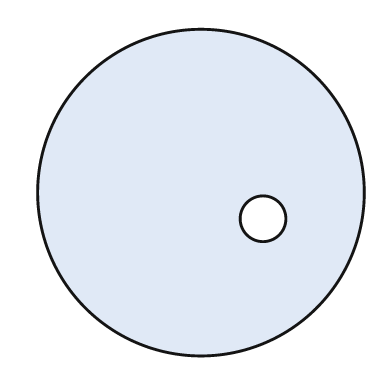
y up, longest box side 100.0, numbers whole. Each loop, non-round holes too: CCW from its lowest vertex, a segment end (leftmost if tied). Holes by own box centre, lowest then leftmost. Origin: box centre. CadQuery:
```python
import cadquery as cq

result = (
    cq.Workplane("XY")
    .moveTo(0.0, 0.0)
    .circle(50.0)
    .moveTo(19.0, -8.0)
    .circle(7.0)
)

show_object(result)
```